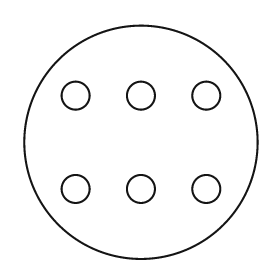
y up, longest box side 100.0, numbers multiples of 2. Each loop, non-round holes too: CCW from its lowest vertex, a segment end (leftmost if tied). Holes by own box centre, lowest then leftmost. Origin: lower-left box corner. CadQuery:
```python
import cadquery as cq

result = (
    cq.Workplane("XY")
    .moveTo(50.0, 50.0)
    .circle(50.0)
    .moveTo(22.0, 30.0)
    .circle(6.0)
    .moveTo(50.0, 30.0)
    .circle(6.0)
    .moveTo(78.0, 30.0)
    .circle(6.0)
    .moveTo(22.0, 70.0)
    .circle(6.0)
    .moveTo(50.0, 70.0)
    .circle(6.0)
    .moveTo(78.0, 70.0)
    .circle(6.0)
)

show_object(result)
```